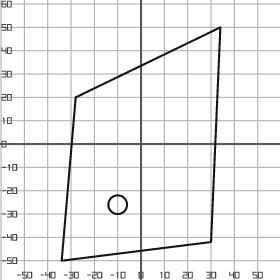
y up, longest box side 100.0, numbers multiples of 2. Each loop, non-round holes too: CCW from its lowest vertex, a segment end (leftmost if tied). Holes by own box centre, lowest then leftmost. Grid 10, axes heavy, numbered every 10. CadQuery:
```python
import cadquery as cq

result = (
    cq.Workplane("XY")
    .moveTo(-34.0, -50.0)
    .lineTo(30.0, -42.0)
    .lineTo(34.0, 50.0)
    .lineTo(-28.0, 20.0)
    .close()
    .moveTo(-10.0, -26.0)
    .circle(4.0)
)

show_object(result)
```